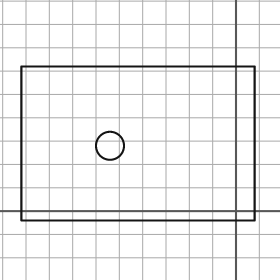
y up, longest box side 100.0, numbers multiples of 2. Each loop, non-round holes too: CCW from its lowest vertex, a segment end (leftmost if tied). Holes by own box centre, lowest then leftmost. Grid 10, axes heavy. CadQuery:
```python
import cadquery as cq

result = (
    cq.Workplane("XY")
    .moveTo(-92.0, -4.0)
    .lineTo(8.0, -4.0)
    .lineTo(8.0, 62.0)
    .lineTo(-92.0, 62.0)
    .close()
    .moveTo(-54.0, 28.0)
    .circle(6.0)
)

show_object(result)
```